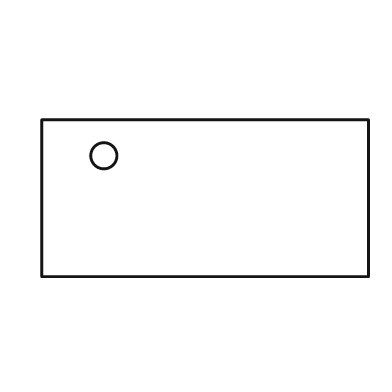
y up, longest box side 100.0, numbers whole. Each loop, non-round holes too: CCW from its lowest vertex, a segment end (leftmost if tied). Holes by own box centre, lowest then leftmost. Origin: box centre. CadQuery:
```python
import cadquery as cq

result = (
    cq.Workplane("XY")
    .moveTo(-50.0, -24.0)
    .lineTo(50.0, -24.0)
    .lineTo(50.0, 24.0)
    .lineTo(-50.0, 24.0)
    .close()
    .moveTo(-31.0, 13.0)
    .circle(4.0)
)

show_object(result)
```